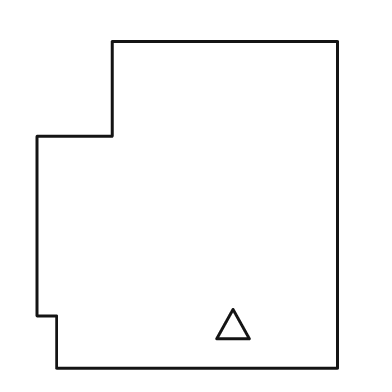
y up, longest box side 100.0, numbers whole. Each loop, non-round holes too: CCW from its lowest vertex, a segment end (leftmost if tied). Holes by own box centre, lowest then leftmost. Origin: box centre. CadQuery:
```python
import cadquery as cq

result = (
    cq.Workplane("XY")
    .moveTo(-40.0, -50.0)
    .lineTo(46.0, -50.0)
    .lineTo(46.0, 50.0)
    .lineTo(-23.0, 50.0)
    .lineTo(-23.0, 21.0)
    .lineTo(-46.0, 21.0)
    .lineTo(-46.0, -34.0)
    .lineTo(-40.0, -34.0)
    .close()
    .moveTo(9.0, -41.0)
    .lineTo(19.0, -41.0)
    .lineTo(14.0, -32.0)
    .close()
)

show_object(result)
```